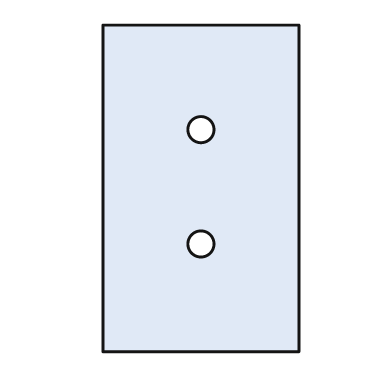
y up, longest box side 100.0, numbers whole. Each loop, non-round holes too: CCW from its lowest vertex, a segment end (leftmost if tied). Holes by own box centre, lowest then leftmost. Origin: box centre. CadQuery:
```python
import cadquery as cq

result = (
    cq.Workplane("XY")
    .moveTo(-30.0, -50.0)
    .lineTo(30.0, -50.0)
    .lineTo(30.0, 50.0)
    .lineTo(-30.0, 50.0)
    .close()
    .moveTo(0.0, -17.0)
    .circle(4.0)
    .moveTo(0.0, 18.0)
    .circle(4.0)
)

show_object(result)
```